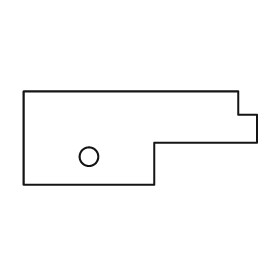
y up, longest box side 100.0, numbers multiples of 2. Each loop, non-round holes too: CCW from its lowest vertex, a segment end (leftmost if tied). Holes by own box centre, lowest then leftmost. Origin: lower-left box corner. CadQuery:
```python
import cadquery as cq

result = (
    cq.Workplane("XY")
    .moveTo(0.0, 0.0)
    .lineTo(56.0, 0.0)
    .lineTo(56.0, 18.0)
    .lineTo(100.0, 18.0)
    .lineTo(100.0, 30.0)
    .lineTo(92.0, 30.0)
    .lineTo(92.0, 40.0)
    .lineTo(0.0, 40.0)
    .close()
    .moveTo(28.0, 12.0)
    .circle(4.0)
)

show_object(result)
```